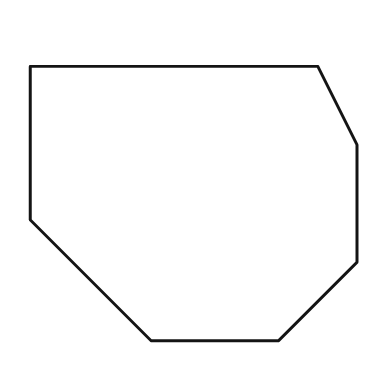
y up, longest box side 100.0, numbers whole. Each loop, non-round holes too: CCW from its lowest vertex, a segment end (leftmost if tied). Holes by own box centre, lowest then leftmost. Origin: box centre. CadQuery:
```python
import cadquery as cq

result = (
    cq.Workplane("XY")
    .moveTo(-13.0, -42.0)
    .lineTo(26.0, -42.0)
    .lineTo(50.0, -18.0)
    .lineTo(50.0, 18.0)
    .lineTo(38.0, 42.0)
    .lineTo(-50.0, 42.0)
    .lineTo(-50.0, -5.0)
    .close()
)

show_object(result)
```